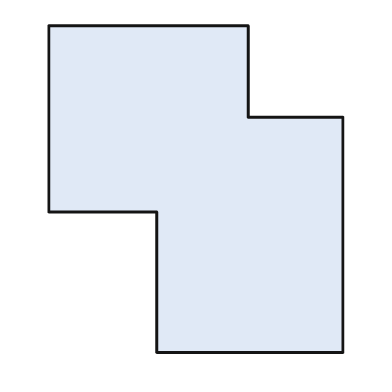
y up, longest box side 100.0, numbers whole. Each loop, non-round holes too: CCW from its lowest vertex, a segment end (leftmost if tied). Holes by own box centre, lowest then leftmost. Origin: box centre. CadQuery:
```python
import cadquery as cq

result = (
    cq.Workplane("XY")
    .moveTo(-12.0, -50.0)
    .lineTo(45.0, -50.0)
    .lineTo(45.0, 22.0)
    .lineTo(16.0, 22.0)
    .lineTo(16.0, 50.0)
    .lineTo(-45.0, 50.0)
    .lineTo(-45.0, -7.0)
    .lineTo(-12.0, -7.0)
    .close()
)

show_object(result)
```